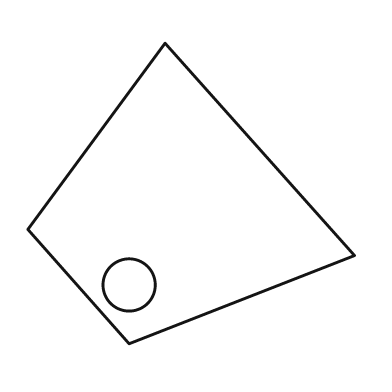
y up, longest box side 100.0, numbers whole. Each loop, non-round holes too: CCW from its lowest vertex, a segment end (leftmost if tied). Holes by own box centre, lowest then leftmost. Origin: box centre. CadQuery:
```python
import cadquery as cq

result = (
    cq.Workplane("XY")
    .moveTo(-19.0, -46.0)
    .lineTo(50.0, -19.0)
    .lineTo(-8.0, 46.0)
    .lineTo(-50.0, -11.0)
    .close()
    .moveTo(-19.0, -28.0)
    .circle(8.0)
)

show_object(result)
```